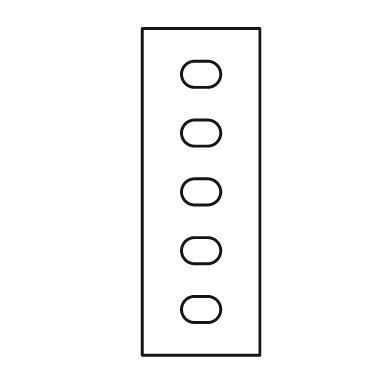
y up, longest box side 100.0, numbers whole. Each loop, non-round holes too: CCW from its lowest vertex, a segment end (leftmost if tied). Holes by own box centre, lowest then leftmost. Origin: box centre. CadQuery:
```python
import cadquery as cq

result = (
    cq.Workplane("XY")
    .moveTo(-18.0, -50.0)
    .lineTo(18.0, -50.0)
    .lineTo(18.0, 50.0)
    .lineTo(-18.0, 50.0)
    .close()
    .moveTo(-2.0, -40.0)
    .lineTo(2.0, -40.0)
    .threePointArc((6.0, -36.0), (2.0, -32.0))
    .lineTo(-2.0, -32.0)
    .threePointArc((-6.0, -36.0), (-2.0, -40.0))
    .close()
    .moveTo(-2.0, -22.0)
    .lineTo(2.0, -22.0)
    .threePointArc((6.0, -18.0), (2.0, -14.0))
    .lineTo(-2.0, -14.0)
    .threePointArc((-6.0, -18.0), (-2.0, -22.0))
    .close()
    .moveTo(-2.0, -4.0)
    .lineTo(2.0, -4.0)
    .threePointArc((6.0, 0.0), (2.0, 4.0))
    .lineTo(-2.0, 4.0)
    .threePointArc((-6.0, 0.0), (-2.0, -4.0))
    .close()
    .moveTo(-2.0, 14.0)
    .lineTo(2.0, 14.0)
    .threePointArc((6.0, 18.0), (2.0, 22.0))
    .lineTo(-2.0, 22.0)
    .threePointArc((-6.0, 18.0), (-2.0, 14.0))
    .close()
    .moveTo(-2.0, 32.0)
    .lineTo(2.0, 32.0)
    .threePointArc((6.0, 36.0), (2.0, 40.0))
    .lineTo(-2.0, 40.0)
    .threePointArc((-6.0, 36.0), (-2.0, 32.0))
    .close()
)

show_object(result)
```